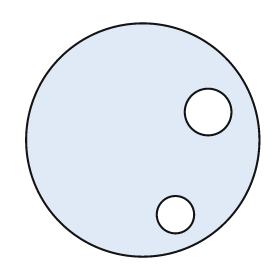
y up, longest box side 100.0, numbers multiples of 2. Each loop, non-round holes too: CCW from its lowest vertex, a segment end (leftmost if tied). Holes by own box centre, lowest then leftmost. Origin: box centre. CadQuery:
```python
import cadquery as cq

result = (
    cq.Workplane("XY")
    .moveTo(0.0, 0.0)
    .circle(50.0)
    .moveTo(14.0, -32.0)
    .circle(8.0)
    .moveTo(28.0, 12.0)
    .circle(10.0)
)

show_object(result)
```